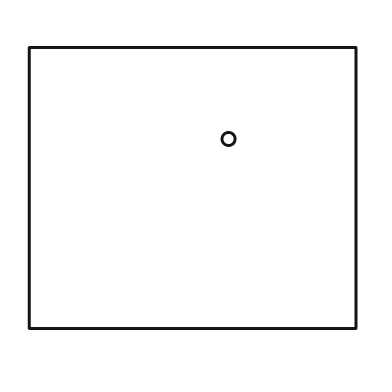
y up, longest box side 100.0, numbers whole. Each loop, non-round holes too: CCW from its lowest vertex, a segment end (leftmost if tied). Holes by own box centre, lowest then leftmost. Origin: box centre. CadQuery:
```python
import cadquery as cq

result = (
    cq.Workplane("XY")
    .moveTo(-50.0, -43.0)
    .lineTo(50.0, -43.0)
    .lineTo(50.0, 43.0)
    .lineTo(-50.0, 43.0)
    .close()
    .moveTo(11.0, 15.0)
    .circle(2.0)
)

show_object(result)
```